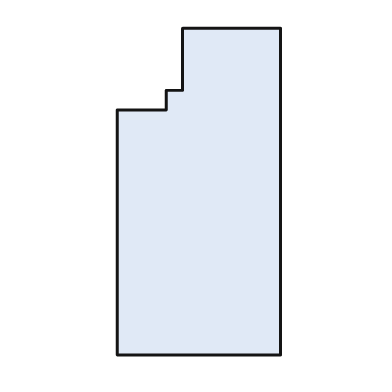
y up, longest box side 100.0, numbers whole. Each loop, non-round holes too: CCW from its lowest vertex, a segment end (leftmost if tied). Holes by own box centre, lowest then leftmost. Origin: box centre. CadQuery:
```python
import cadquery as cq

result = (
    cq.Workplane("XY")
    .moveTo(-25.0, -50.0)
    .lineTo(25.0, -50.0)
    .lineTo(25.0, 50.0)
    .lineTo(-5.0, 50.0)
    .lineTo(-5.0, 31.0)
    .lineTo(-10.0, 31.0)
    .lineTo(-10.0, 25.0)
    .lineTo(-25.0, 25.0)
    .close()
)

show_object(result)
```